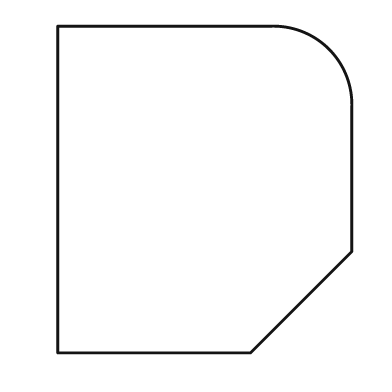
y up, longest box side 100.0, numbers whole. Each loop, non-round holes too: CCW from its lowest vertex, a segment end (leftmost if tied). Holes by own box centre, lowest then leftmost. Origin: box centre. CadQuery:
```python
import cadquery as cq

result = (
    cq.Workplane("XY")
    .moveTo(-45.0, -50.0)
    .lineTo(14.0, -50.0)
    .lineTo(45.0, -19.0)
    .lineTo(45.0, 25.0)
    .threePointArc((38.0, 43.0), (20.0, 50.0))
    .lineTo(-45.0, 50.0)
    .close()
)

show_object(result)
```